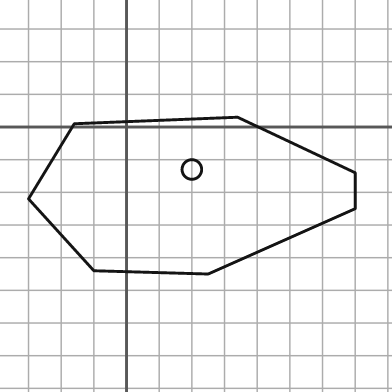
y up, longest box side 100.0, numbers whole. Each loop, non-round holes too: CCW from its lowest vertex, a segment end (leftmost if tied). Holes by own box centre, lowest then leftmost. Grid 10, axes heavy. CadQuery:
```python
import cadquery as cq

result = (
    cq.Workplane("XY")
    .moveTo(25.0, -45.0)
    .lineTo(70.0, -25.0)
    .lineTo(70.0, -14.0)
    .lineTo(34.0, 3.0)
    .lineTo(-16.0, 1.0)
    .lineTo(-30.0, -22.0)
    .lineTo(-10.0, -44.0)
    .close()
    .moveTo(20.0, -13.0)
    .circle(3.0)
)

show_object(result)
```